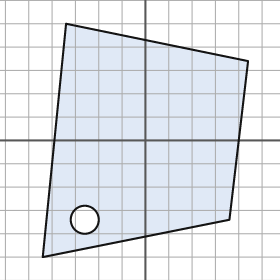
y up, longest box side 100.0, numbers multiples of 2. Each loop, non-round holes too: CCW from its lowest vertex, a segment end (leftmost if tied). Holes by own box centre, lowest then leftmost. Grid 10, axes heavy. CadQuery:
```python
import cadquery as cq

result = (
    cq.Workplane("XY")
    .moveTo(-44.0, -50.0)
    .lineTo(36.0, -34.0)
    .lineTo(44.0, 34.0)
    .lineTo(-34.0, 50.0)
    .close()
    .moveTo(-26.0, -34.0)
    .circle(6.0)
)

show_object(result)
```